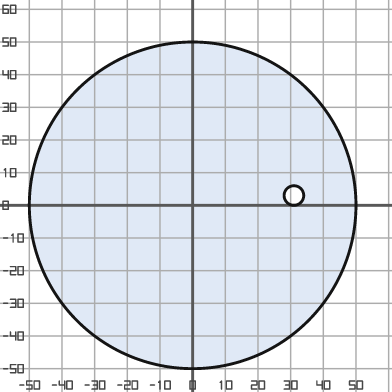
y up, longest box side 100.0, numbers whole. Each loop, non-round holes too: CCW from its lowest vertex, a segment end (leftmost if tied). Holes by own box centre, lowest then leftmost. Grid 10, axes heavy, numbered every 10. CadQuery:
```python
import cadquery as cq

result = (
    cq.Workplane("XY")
    .moveTo(0.0, 0.0)
    .circle(50.0)
    .moveTo(31.0, 3.0)
    .circle(3.0)
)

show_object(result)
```